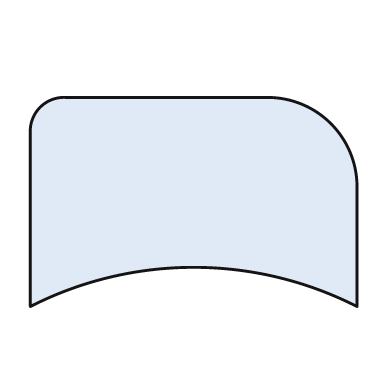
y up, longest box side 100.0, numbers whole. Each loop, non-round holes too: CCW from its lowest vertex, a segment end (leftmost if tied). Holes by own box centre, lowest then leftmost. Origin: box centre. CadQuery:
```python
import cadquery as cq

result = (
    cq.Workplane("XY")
    .moveTo(-50.0, -32.0)
    .threePointArc((0.0, -20.0), (50.0, -32.0))
    .lineTo(50.0, 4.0)
    .threePointArc((42.0, 24.0), (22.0, 32.0))
    .lineTo(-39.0, 32.0)
    .threePointArc((-47.0, 29.0), (-50.0, 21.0))
    .close()
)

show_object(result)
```